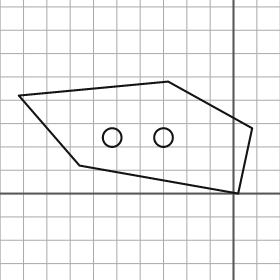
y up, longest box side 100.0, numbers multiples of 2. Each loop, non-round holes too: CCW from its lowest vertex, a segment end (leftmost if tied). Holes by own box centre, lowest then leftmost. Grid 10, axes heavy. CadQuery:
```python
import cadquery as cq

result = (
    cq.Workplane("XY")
    .moveTo(2.0, 0.0)
    .lineTo(8.0, 28.0)
    .lineTo(-28.0, 48.0)
    .lineTo(-92.0, 42.0)
    .lineTo(-66.0, 12.0)
    .close()
    .moveTo(-52.0, 24.0)
    .circle(4.0)
    .moveTo(-30.0, 24.0)
    .circle(4.0)
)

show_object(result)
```